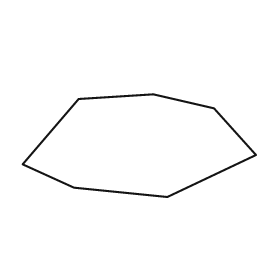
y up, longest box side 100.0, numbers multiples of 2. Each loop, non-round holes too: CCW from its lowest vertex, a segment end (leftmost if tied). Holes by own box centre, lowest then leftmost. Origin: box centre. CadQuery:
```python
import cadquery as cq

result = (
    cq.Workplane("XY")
    .moveTo(12.0, -22.0)
    .lineTo(50.0, -4.0)
    .lineTo(32.0, 16.0)
    .lineTo(6.0, 22.0)
    .lineTo(-26.0, 20.0)
    .lineTo(-50.0, -8.0)
    .lineTo(-28.0, -18.0)
    .close()
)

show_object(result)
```